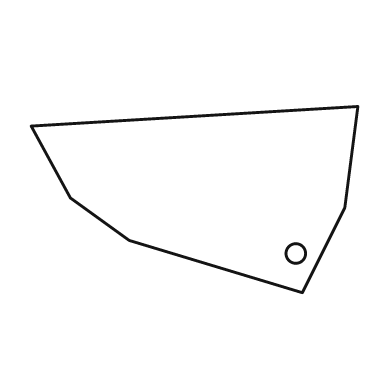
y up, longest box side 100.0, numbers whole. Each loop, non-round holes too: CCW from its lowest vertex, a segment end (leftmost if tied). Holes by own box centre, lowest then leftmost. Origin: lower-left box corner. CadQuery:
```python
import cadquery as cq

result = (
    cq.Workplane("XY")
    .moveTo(83.0, 0.0)
    .lineTo(96.0, 26.0)
    .lineTo(100.0, 57.0)
    .lineTo(0.0, 51.0)
    .lineTo(12.0, 29.0)
    .lineTo(30.0, 16.0)
    .close()
    .moveTo(81.0, 12.0)
    .circle(3.0)
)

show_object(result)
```